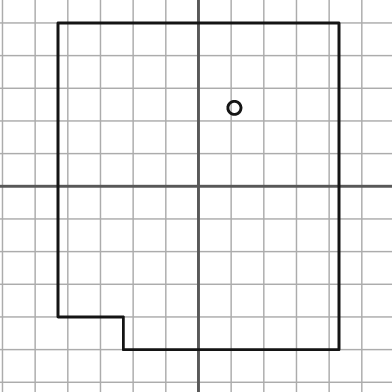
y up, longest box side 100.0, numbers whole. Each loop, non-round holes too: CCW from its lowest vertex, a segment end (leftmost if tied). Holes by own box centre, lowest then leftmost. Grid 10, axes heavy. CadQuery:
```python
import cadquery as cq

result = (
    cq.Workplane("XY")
    .moveTo(-23.0, -50.0)
    .lineTo(43.0, -50.0)
    .lineTo(43.0, 50.0)
    .lineTo(-43.0, 50.0)
    .lineTo(-43.0, -40.0)
    .lineTo(-23.0, -40.0)
    .close()
    .moveTo(11.0, 24.0)
    .circle(2.0)
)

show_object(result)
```